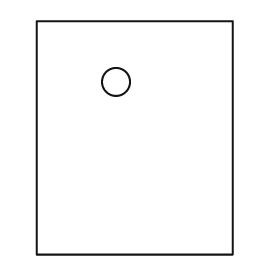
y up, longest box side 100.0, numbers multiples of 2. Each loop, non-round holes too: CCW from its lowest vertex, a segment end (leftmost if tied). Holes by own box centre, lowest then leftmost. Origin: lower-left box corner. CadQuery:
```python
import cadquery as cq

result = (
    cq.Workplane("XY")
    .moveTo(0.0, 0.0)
    .lineTo(84.0, 0.0)
    .lineTo(84.0, 100.0)
    .lineTo(0.0, 100.0)
    .close()
    .moveTo(34.0, 74.0)
    .circle(6.0)
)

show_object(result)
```